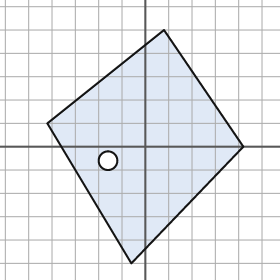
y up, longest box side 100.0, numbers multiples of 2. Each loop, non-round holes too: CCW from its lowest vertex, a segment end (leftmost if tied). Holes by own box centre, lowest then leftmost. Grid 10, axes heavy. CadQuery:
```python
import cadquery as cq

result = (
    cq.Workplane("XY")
    .moveTo(-6.0, -50.0)
    .lineTo(42.0, 0.0)
    .lineTo(8.0, 50.0)
    .lineTo(-42.0, 10.0)
    .close()
    .moveTo(-16.0, -6.0)
    .circle(4.0)
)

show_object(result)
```